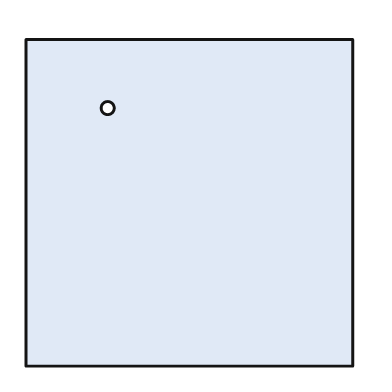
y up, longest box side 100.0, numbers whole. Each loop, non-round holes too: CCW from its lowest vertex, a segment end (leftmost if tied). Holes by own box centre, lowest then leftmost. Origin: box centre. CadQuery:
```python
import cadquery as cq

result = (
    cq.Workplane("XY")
    .moveTo(-50.0, -50.0)
    .lineTo(50.0, -50.0)
    .lineTo(50.0, 50.0)
    .lineTo(-50.0, 50.0)
    .close()
    .moveTo(-25.0, 29.0)
    .circle(2.0)
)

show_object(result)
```